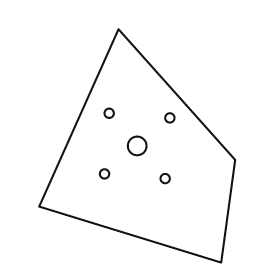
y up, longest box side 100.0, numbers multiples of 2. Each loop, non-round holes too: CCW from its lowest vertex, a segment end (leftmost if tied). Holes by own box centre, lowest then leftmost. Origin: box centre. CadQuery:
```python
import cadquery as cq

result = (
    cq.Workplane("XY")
    .moveTo(36.0, -50.0)
    .lineTo(42.0, -6.0)
    .lineTo(-8.0, 50.0)
    .lineTo(-42.0, -26.0)
    .close()
    .moveTo(12.0, -14.0)
    .circle(2.0)
    .moveTo(-14.0, -12.0)
    .circle(2.0)
    .moveTo(0.0, 0.0)
    .circle(4.0)
    .moveTo(14.0, 12.0)
    .circle(2.0)
    .moveTo(-12.0, 14.0)
    .circle(2.0)
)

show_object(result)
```